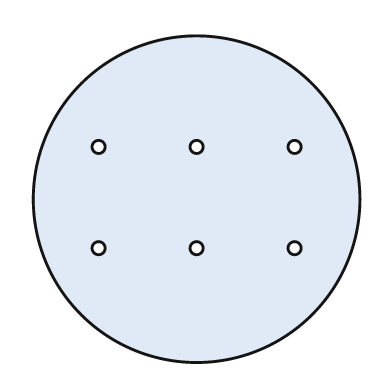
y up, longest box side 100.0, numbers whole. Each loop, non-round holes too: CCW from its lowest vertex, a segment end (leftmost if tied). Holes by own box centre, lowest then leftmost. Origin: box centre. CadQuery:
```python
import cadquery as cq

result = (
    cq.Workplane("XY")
    .moveTo(0.0, 0.0)
    .circle(50.0)
    .moveTo(-30.0, -15.0)
    .circle(2.0)
    .moveTo(0.0, -15.0)
    .circle(2.0)
    .moveTo(30.0, -15.0)
    .circle(2.0)
    .moveTo(-30.0, 16.0)
    .circle(2.0)
    .moveTo(0.0, 16.0)
    .circle(2.0)
    .moveTo(30.0, 16.0)
    .circle(2.0)
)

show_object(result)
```